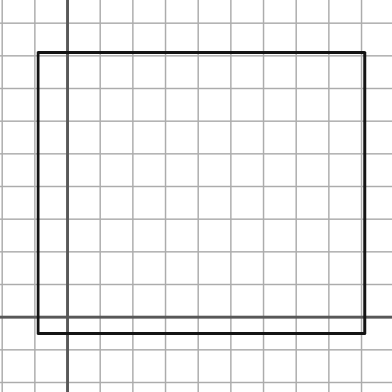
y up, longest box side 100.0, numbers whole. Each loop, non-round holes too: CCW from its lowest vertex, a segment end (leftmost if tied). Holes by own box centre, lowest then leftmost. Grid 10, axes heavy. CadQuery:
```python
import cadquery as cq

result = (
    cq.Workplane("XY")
    .moveTo(-9.0, -5.0)
    .lineTo(91.0, -5.0)
    .lineTo(91.0, 81.0)
    .lineTo(-9.0, 81.0)
    .close()
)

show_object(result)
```